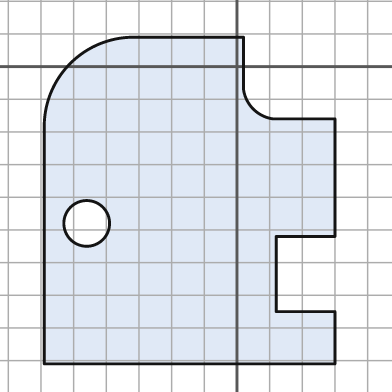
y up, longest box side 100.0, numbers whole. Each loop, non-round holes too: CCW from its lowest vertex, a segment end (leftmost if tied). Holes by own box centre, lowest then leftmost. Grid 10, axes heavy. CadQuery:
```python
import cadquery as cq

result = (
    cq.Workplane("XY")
    .moveTo(-59.0, -91.0)
    .lineTo(30.0, -91.0)
    .lineTo(30.0, -75.0)
    .lineTo(12.0, -75.0)
    .lineTo(12.0, -52.0)
    .lineTo(30.0, -52.0)
    .lineTo(30.0, -16.0)
    .lineTo(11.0, -16.0)
    .threePointArc((5.0, -13.0), (2.0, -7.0))
    .lineTo(2.0, 9.0)
    .lineTo(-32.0, 9.0)
    .threePointArc((-51.0, 1.0), (-59.0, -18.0))
    .close()
    .moveTo(-46.0, -48.0)
    .circle(7.0)
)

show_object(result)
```